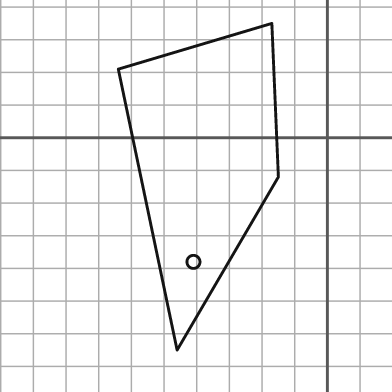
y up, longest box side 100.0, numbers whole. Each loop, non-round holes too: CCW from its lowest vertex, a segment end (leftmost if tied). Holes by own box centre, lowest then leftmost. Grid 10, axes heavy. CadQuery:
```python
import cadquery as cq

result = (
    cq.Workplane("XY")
    .moveTo(-46.0, -65.0)
    .lineTo(-15.0, -12.0)
    .lineTo(-17.0, 35.0)
    .lineTo(-64.0, 21.0)
    .close()
    .moveTo(-41.0, -38.0)
    .circle(2.0)
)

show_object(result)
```